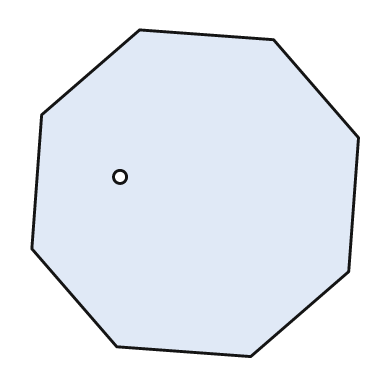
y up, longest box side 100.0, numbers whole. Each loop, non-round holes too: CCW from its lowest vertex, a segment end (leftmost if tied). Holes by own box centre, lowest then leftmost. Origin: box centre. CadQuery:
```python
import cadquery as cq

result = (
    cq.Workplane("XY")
    .moveTo(17.0, -50.0)
    .lineTo(47.0, -24.0)
    .lineTo(50.0, 17.0)
    .lineTo(24.0, 47.0)
    .lineTo(-17.0, 50.0)
    .lineTo(-47.0, 24.0)
    .lineTo(-50.0, -17.0)
    .lineTo(-24.0, -47.0)
    .close()
    .moveTo(-23.0, 5.0)
    .circle(2.0)
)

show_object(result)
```